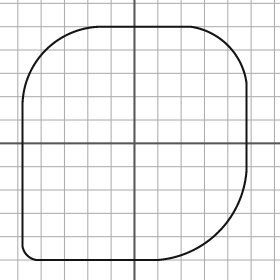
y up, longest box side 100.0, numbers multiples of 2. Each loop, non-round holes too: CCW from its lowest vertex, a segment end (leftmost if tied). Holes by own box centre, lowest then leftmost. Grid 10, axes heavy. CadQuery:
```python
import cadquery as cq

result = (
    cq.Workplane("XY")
    .moveTo(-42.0, -50.0)
    .lineTo(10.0, -50.0)
    .threePointArc((36.0, -38.0), (48.0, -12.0))
    .lineTo(48.0, 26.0)
    .threePointArc((40.0, 42.0), (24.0, 50.0))
    .lineTo(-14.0, 50.0)
    .threePointArc((-38.0, 40.0), (-48.0, 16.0))
    .lineTo(-48.0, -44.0)
    .threePointArc((-46.0, -48.0), (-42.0, -50.0))
    .close()
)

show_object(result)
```